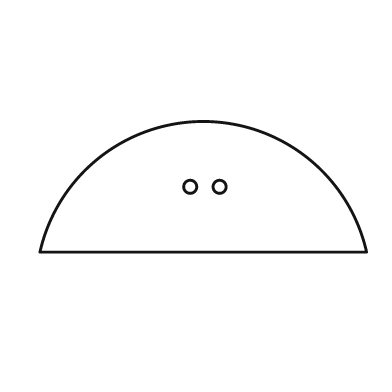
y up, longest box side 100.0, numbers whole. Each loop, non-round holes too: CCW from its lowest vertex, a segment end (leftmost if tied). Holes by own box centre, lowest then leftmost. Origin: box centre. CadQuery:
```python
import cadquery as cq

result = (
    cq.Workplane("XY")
    .moveTo(-50.0, -20.0)
    .lineTo(50.0, -20.0)
    .threePointArc((0.0, 20.0), (-50.0, -20.0))
    .close()
    .moveTo(-4.0, 0.0)
    .circle(2.0)
    .moveTo(5.0, 0.0)
    .circle(2.0)
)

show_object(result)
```